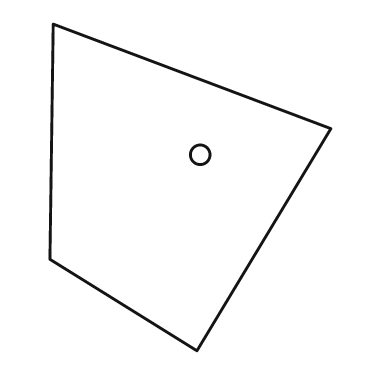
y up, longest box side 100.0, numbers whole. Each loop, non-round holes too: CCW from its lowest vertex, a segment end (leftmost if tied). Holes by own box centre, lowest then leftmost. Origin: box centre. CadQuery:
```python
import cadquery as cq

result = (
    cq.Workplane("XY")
    .moveTo(2.0, -50.0)
    .lineTo(43.0, 18.0)
    .lineTo(-42.0, 50.0)
    .lineTo(-43.0, -22.0)
    .close()
    .moveTo(3.0, 10.0)
    .circle(3.0)
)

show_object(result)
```